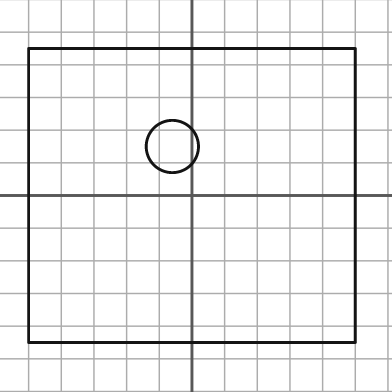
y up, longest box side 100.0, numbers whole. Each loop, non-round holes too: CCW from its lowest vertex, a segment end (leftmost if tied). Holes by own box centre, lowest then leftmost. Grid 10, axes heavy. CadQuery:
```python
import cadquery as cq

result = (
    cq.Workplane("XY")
    .moveTo(-50.0, -45.0)
    .lineTo(50.0, -45.0)
    .lineTo(50.0, 45.0)
    .lineTo(-50.0, 45.0)
    .close()
    .moveTo(-6.0, 15.0)
    .circle(8.0)
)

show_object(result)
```